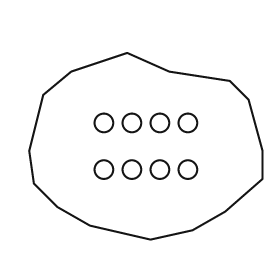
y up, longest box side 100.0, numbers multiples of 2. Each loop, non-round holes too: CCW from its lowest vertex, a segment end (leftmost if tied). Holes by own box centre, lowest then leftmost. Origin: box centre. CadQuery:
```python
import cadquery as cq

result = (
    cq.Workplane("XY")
    .moveTo(2.0, -40.0)
    .lineTo(20.0, -36.0)
    .lineTo(34.0, -28.0)
    .lineTo(50.0, -14.0)
    .lineTo(50.0, -2.0)
    .lineTo(44.0, 20.0)
    .lineTo(36.0, 28.0)
    .lineTo(10.0, 32.0)
    .lineTo(-8.0, 40.0)
    .lineTo(-32.0, 32.0)
    .lineTo(-44.0, 22.0)
    .lineTo(-50.0, -2.0)
    .lineTo(-48.0, -16.0)
    .lineTo(-38.0, -26.0)
    .lineTo(-24.0, -34.0)
    .close()
    .moveTo(-18.0, -10.0)
    .circle(4.0)
    .moveTo(-6.0, -10.0)
    .circle(4.0)
    .moveTo(6.0, -10.0)
    .circle(4.0)
    .moveTo(18.0, -10.0)
    .circle(4.0)
    .moveTo(-18.0, 10.0)
    .circle(4.0)
    .moveTo(-6.0, 10.0)
    .circle(4.0)
    .moveTo(6.0, 10.0)
    .circle(4.0)
    .moveTo(18.0, 10.0)
    .circle(4.0)
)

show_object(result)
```